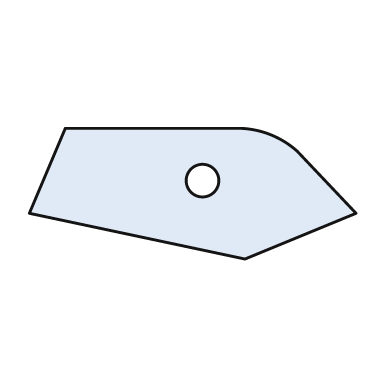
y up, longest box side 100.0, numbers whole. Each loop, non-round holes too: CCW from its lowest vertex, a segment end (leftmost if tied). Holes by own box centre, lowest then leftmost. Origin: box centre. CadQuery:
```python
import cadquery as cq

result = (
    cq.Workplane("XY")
    .moveTo(16.0, -20.0)
    .lineTo(50.0, -6.0)
    .lineTo(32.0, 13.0)
    .threePointArc((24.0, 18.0), (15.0, 20.0))
    .lineTo(-39.0, 20.0)
    .lineTo(-50.0, -6.0)
    .close()
    .moveTo(3.0, 4.0)
    .circle(5.0)
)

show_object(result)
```